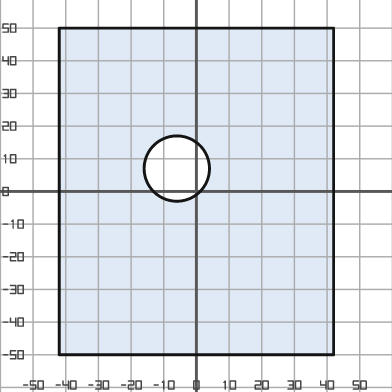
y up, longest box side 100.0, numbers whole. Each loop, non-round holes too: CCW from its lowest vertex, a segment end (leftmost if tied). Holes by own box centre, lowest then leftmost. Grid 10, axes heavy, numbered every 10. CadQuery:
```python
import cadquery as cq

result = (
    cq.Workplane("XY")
    .moveTo(-42.0, -50.0)
    .lineTo(42.0, -50.0)
    .lineTo(42.0, 50.0)
    .lineTo(-42.0, 50.0)
    .close()
    .moveTo(-6.0, 7.0)
    .circle(10.0)
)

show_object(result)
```